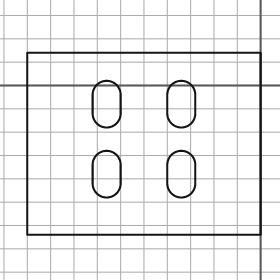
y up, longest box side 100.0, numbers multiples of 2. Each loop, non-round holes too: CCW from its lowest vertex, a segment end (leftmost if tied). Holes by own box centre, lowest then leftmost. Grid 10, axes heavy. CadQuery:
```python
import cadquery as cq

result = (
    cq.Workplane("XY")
    .moveTo(-100.0, -64.0)
    .lineTo(0.0, -64.0)
    .lineTo(0.0, 14.0)
    .lineTo(-100.0, 14.0)
    .close()
    .moveTo(-72.0, -42.0)
    .threePointArc((-66.0, -48.0), (-60.0, -42.0))
    .lineTo(-60.0, -34.0)
    .threePointArc((-66.0, -28.0), (-72.0, -34.0))
    .close()
    .moveTo(-40.0, -42.0)
    .threePointArc((-34.0, -48.0), (-28.0, -42.0))
    .lineTo(-28.0, -34.0)
    .threePointArc((-34.0, -28.0), (-40.0, -34.0))
    .close()
    .moveTo(-72.0, -12.0)
    .threePointArc((-66.0, -18.0), (-60.0, -12.0))
    .lineTo(-60.0, -4.0)
    .threePointArc((-66.0, 2.0), (-72.0, -4.0))
    .close()
    .moveTo(-40.0, -12.0)
    .threePointArc((-34.0, -18.0), (-28.0, -12.0))
    .lineTo(-28.0, -4.0)
    .threePointArc((-34.0, 2.0), (-40.0, -4.0))
    .close()
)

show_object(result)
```